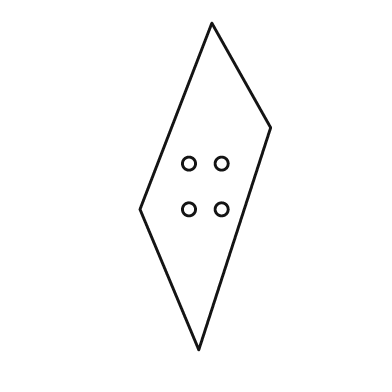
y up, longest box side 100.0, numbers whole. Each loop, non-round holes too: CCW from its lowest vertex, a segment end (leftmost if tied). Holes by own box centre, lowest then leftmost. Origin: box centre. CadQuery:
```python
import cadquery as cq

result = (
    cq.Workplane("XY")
    .moveTo(-2.0, -50.0)
    .lineTo(20.0, 18.0)
    .lineTo(2.0, 50.0)
    .lineTo(-20.0, -7.0)
    .close()
    .moveTo(-5.0, -7.0)
    .circle(2.0)
    .moveTo(5.0, -7.0)
    .circle(2.0)
    .moveTo(-5.0, 7.0)
    .circle(2.0)
    .moveTo(5.0, 7.0)
    .circle(2.0)
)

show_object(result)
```